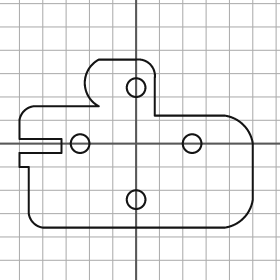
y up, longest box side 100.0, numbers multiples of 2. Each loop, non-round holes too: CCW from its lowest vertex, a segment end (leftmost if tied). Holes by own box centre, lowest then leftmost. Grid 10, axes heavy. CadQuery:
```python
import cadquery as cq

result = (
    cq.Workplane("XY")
    .moveTo(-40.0, -36.0)
    .lineTo(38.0, -36.0)
    .threePointArc((46.0, -32.0), (50.0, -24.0))
    .lineTo(50.0, 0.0)
    .threePointArc((46.0, 8.0), (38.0, 12.0))
    .lineTo(8.0, 12.0)
    .lineTo(8.0, 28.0)
    .threePointArc((6.0, 34.0), (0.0, 36.0))
    .lineTo(-16.0, 36.0)
    .threePointArc((-22.0, 26.0), (-16.0, 16.0))
    .lineTo(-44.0, 16.0)
    .threePointArc((-48.0, 14.0), (-50.0, 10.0))
    .lineTo(-50.0, 2.0)
    .lineTo(-32.0, 2.0)
    .lineTo(-32.0, -4.0)
    .lineTo(-50.0, -4.0)
    .lineTo(-50.0, -10.0)
    .lineTo(-46.0, -10.0)
    .lineTo(-46.0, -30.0)
    .threePointArc((-44.0, -34.0), (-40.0, -36.0))
    .close()
    .moveTo(0.0, -24.0)
    .circle(4.0)
    .moveTo(-24.0, 0.0)
    .circle(4.0)
    .moveTo(24.0, 0.0)
    .circle(4.0)
    .moveTo(0.0, 24.0)
    .circle(4.0)
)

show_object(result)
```